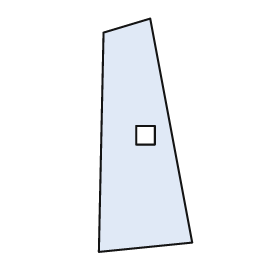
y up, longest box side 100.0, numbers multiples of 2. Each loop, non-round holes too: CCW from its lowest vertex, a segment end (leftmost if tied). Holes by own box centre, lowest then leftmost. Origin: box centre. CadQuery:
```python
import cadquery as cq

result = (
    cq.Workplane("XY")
    .moveTo(-20.0, -50.0)
    .lineTo(20.0, -46.0)
    .lineTo(2.0, 50.0)
    .lineTo(-18.0, 44.0)
    .close()
    .moveTo(-4.0, -4.0)
    .lineTo(4.0, -4.0)
    .lineTo(4.0, 4.0)
    .lineTo(-4.0, 4.0)
    .close()
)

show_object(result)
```